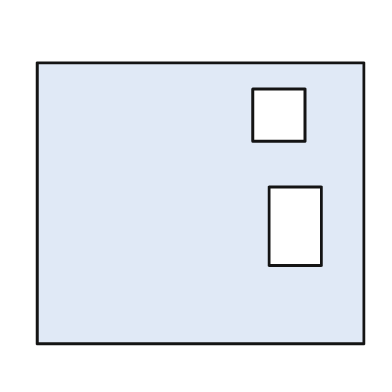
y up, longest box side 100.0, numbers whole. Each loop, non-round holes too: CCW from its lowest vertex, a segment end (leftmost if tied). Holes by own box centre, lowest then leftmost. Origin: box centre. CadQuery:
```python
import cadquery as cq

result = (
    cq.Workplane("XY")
    .moveTo(-50.0, -43.0)
    .lineTo(50.0, -43.0)
    .lineTo(50.0, 43.0)
    .lineTo(-50.0, 43.0)
    .close()
    .moveTo(21.0, -19.0)
    .lineTo(37.0, -19.0)
    .lineTo(37.0, 5.0)
    .lineTo(21.0, 5.0)
    .close()
    .moveTo(16.0, 19.0)
    .lineTo(32.0, 19.0)
    .lineTo(32.0, 35.0)
    .lineTo(16.0, 35.0)
    .close()
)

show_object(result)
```